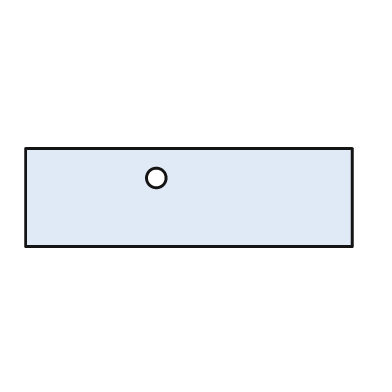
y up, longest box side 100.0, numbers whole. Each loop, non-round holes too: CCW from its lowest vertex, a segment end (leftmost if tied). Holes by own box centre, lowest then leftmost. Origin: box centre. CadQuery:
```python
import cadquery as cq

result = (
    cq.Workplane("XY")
    .moveTo(-50.0, -15.0)
    .lineTo(50.0, -15.0)
    .lineTo(50.0, 15.0)
    .lineTo(-50.0, 15.0)
    .close()
    .moveTo(-10.0, 6.0)
    .circle(3.0)
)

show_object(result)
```